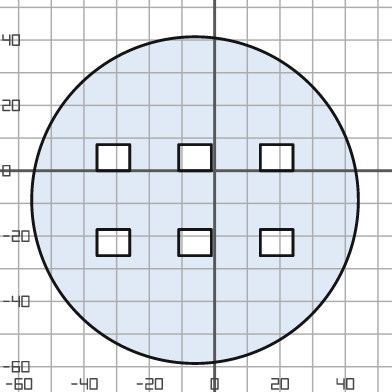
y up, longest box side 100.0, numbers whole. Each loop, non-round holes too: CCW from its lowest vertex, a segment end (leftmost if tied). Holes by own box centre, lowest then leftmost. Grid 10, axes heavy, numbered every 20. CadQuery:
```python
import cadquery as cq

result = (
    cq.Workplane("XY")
    .moveTo(-6.0, -9.0)
    .circle(50.0)
    .moveTo(-36.0, -26.0)
    .lineTo(-26.0, -26.0)
    .lineTo(-26.0, -18.0)
    .lineTo(-36.0, -18.0)
    .close()
    .moveTo(-11.0, -26.0)
    .lineTo(-1.0, -26.0)
    .lineTo(-1.0, -18.0)
    .lineTo(-11.0, -18.0)
    .close()
    .moveTo(14.0, -26.0)
    .lineTo(24.0, -26.0)
    .lineTo(24.0, -18.0)
    .lineTo(14.0, -18.0)
    .close()
    .moveTo(-36.0, 0.0)
    .lineTo(-26.0, 0.0)
    .lineTo(-26.0, 8.0)
    .lineTo(-36.0, 8.0)
    .close()
    .moveTo(-11.0, 0.0)
    .lineTo(-1.0, 0.0)
    .lineTo(-1.0, 8.0)
    .lineTo(-11.0, 8.0)
    .close()
    .moveTo(14.0, 0.0)
    .lineTo(24.0, 0.0)
    .lineTo(24.0, 8.0)
    .lineTo(14.0, 8.0)
    .close()
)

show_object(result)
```